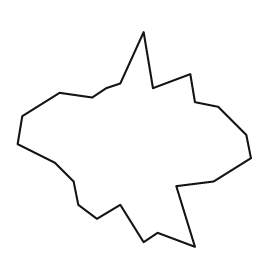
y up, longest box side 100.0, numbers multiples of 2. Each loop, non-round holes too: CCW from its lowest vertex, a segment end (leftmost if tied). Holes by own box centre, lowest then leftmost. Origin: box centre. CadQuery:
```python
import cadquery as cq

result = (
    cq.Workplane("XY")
    .moveTo(26.0, -46.0)
    .lineTo(18.0, -20.0)
    .lineTo(34.0, -18.0)
    .lineTo(50.0, -8.0)
    .lineTo(48.0, 2.0)
    .lineTo(36.0, 14.0)
    .lineTo(26.0, 16.0)
    .lineTo(24.0, 28.0)
    .lineTo(8.0, 22.0)
    .lineTo(4.0, 46.0)
    .lineTo(-6.0, 24.0)
    .lineTo(-12.0, 22.0)
    .lineTo(-18.0, 18.0)
    .lineTo(-32.0, 20.0)
    .lineTo(-48.0, 10.0)
    .lineTo(-50.0, -2.0)
    .lineTo(-34.0, -10.0)
    .lineTo(-26.0, -18.0)
    .lineTo(-24.0, -28.0)
    .lineTo(-16.0, -34.0)
    .lineTo(-6.0, -28.0)
    .lineTo(4.0, -44.0)
    .lineTo(10.0, -40.0)
    .close()
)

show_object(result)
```